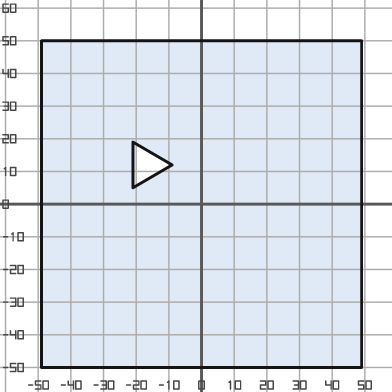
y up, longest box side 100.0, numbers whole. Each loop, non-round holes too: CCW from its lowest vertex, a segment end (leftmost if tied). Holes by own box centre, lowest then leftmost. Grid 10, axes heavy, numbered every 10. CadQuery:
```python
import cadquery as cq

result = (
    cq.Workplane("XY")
    .moveTo(-49.0, -50.0)
    .lineTo(49.0, -50.0)
    .lineTo(49.0, 50.0)
    .lineTo(-49.0, 50.0)
    .close()
    .moveTo(-21.0, 5.0)
    .lineTo(-9.0, 12.0)
    .lineTo(-21.0, 19.0)
    .close()
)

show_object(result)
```